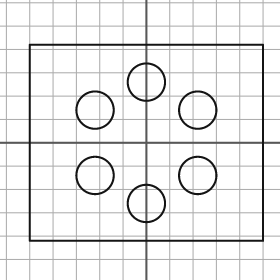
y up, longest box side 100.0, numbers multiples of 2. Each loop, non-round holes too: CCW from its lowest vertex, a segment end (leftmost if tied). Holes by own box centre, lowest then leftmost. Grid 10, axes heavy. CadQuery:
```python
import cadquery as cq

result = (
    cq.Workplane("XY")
    .moveTo(-50.0, -42.0)
    .lineTo(50.0, -42.0)
    .lineTo(50.0, 42.0)
    .lineTo(-50.0, 42.0)
    .close()
    .moveTo(0.0, -26.0)
    .circle(8.0)
    .moveTo(-22.0, -14.0)
    .circle(8.0)
    .moveTo(22.0, -14.0)
    .circle(8.0)
    .moveTo(-22.0, 14.0)
    .circle(8.0)
    .moveTo(22.0, 14.0)
    .circle(8.0)
    .moveTo(0.0, 26.0)
    .circle(8.0)
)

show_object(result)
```